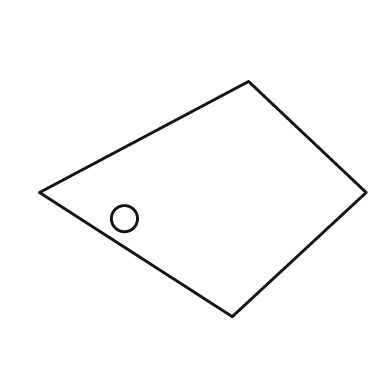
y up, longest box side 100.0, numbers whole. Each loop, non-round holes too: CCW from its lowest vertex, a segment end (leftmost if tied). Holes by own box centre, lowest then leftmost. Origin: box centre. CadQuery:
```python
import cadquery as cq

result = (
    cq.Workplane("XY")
    .moveTo(9.0, -36.0)
    .lineTo(50.0, 2.0)
    .lineTo(14.0, 36.0)
    .lineTo(-50.0, 2.0)
    .close()
    .moveTo(-24.0, -6.0)
    .circle(4.0)
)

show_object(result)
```